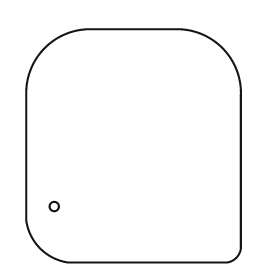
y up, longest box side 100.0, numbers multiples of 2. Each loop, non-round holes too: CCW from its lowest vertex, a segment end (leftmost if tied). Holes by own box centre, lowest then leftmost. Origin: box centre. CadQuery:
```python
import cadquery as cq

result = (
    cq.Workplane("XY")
    .moveTo(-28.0, -50.0)
    .lineTo(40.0, -50.0)
    .threePointArc((44.0, -48.0), (46.0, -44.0))
    .lineTo(46.0, 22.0)
    .threePointArc((38.0, 42.0), (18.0, 50.0))
    .lineTo(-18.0, 50.0)
    .threePointArc((-38.0, 42.0), (-46.0, 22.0))
    .lineTo(-46.0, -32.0)
    .threePointArc((-40.0, -44.0), (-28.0, -50.0))
    .close()
    .moveTo(-34.0, -26.0)
    .circle(2.0)
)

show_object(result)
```